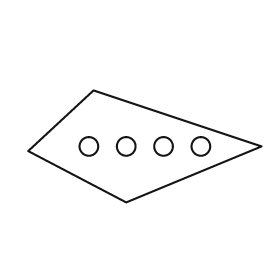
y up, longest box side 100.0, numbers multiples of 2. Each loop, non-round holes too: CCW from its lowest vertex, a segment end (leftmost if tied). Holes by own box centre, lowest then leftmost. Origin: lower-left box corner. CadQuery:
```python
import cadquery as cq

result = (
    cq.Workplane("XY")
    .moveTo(42.0, 0.0)
    .lineTo(100.0, 24.0)
    .lineTo(28.0, 48.0)
    .lineTo(0.0, 22.0)
    .close()
    .moveTo(26.0, 24.0)
    .circle(4.0)
    .moveTo(42.0, 24.0)
    .circle(4.0)
    .moveTo(58.0, 24.0)
    .circle(4.0)
    .moveTo(74.0, 24.0)
    .circle(4.0)
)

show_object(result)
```